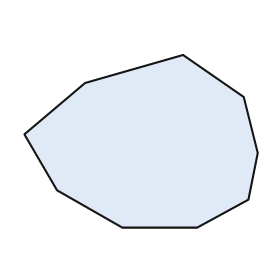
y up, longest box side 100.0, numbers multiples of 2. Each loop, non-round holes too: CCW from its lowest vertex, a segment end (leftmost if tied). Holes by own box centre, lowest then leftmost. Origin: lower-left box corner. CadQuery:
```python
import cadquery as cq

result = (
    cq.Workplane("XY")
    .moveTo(42.0, 0.0)
    .lineTo(74.0, 0.0)
    .lineTo(96.0, 12.0)
    .lineTo(100.0, 32.0)
    .lineTo(94.0, 56.0)
    .lineTo(68.0, 74.0)
    .lineTo(26.0, 62.0)
    .lineTo(0.0, 40.0)
    .lineTo(14.0, 16.0)
    .close()
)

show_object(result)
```